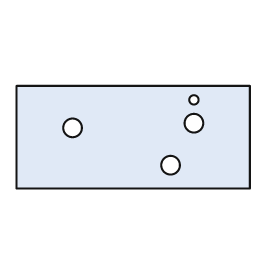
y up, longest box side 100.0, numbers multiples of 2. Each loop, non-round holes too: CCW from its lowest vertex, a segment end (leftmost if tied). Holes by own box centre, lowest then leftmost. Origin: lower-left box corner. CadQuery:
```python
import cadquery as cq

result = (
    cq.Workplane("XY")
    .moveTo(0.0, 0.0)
    .lineTo(100.0, 0.0)
    .lineTo(100.0, 44.0)
    .lineTo(0.0, 44.0)
    .close()
    .moveTo(66.0, 10.0)
    .circle(4.0)
    .moveTo(24.0, 26.0)
    .circle(4.0)
    .moveTo(76.0, 28.0)
    .circle(4.0)
    .moveTo(76.0, 38.0)
    .circle(2.0)
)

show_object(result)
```